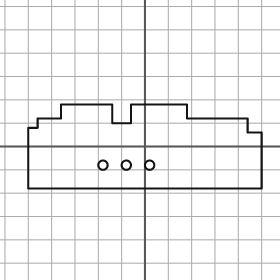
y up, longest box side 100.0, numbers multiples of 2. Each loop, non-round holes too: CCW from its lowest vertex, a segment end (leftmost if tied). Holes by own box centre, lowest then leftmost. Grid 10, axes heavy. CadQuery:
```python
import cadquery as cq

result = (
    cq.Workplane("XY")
    .moveTo(-50.0, -18.0)
    .lineTo(50.0, -18.0)
    .lineTo(50.0, 6.0)
    .lineTo(44.0, 6.0)
    .lineTo(44.0, 12.0)
    .lineTo(18.0, 12.0)
    .lineTo(18.0, 18.0)
    .lineTo(-6.0, 18.0)
    .lineTo(-6.0, 10.0)
    .lineTo(-14.0, 10.0)
    .lineTo(-14.0, 18.0)
    .lineTo(-36.0, 18.0)
    .lineTo(-36.0, 12.0)
    .lineTo(-46.0, 12.0)
    .lineTo(-46.0, 8.0)
    .lineTo(-50.0, 8.0)
    .close()
    .moveTo(-18.0, -8.0)
    .circle(2.0)
    .moveTo(-8.0, -8.0)
    .circle(2.0)
    .moveTo(2.0, -8.0)
    .circle(2.0)
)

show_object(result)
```